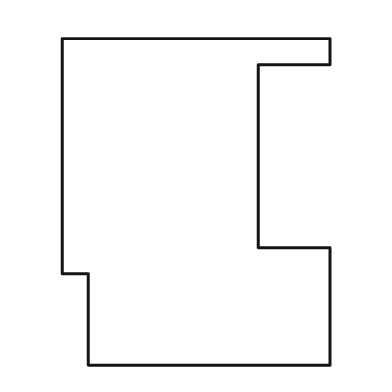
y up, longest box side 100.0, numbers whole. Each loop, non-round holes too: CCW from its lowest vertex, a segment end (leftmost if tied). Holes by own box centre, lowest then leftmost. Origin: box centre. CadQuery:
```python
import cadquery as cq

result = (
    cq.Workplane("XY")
    .moveTo(-33.0, -50.0)
    .lineTo(41.0, -50.0)
    .lineTo(41.0, -14.0)
    .lineTo(19.0, -14.0)
    .lineTo(19.0, 42.0)
    .lineTo(41.0, 42.0)
    .lineTo(41.0, 50.0)
    .lineTo(-41.0, 50.0)
    .lineTo(-41.0, -22.0)
    .lineTo(-33.0, -22.0)
    .close()
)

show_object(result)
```